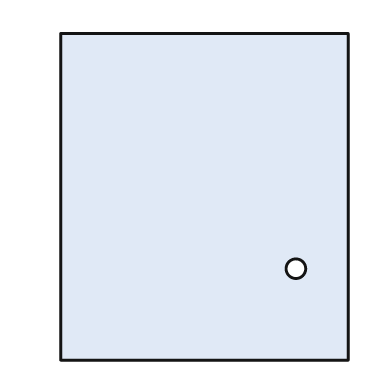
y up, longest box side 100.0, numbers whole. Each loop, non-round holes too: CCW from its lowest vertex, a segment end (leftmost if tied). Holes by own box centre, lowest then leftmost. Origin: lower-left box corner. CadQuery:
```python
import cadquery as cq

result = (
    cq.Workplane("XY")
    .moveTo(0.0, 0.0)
    .lineTo(88.0, 0.0)
    .lineTo(88.0, 100.0)
    .lineTo(0.0, 100.0)
    .close()
    .moveTo(72.0, 28.0)
    .circle(3.0)
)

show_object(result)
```